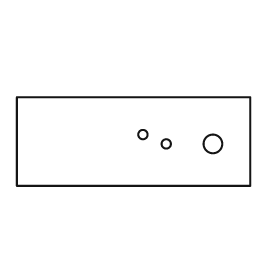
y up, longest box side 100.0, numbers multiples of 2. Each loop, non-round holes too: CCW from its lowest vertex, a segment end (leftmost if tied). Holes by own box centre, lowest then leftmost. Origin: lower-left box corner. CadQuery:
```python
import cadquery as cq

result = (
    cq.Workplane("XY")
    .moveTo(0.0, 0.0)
    .lineTo(100.0, 0.0)
    .lineTo(100.0, 38.0)
    .lineTo(0.0, 38.0)
    .close()
    .moveTo(64.0, 18.0)
    .circle(2.0)
    .moveTo(84.0, 18.0)
    .circle(4.0)
    .moveTo(54.0, 22.0)
    .circle(2.0)
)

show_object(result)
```